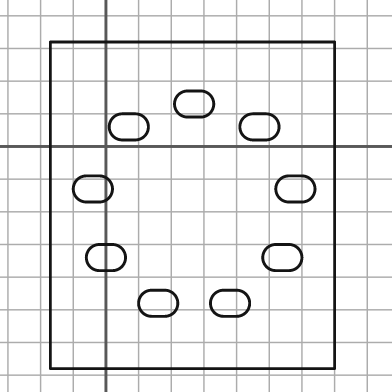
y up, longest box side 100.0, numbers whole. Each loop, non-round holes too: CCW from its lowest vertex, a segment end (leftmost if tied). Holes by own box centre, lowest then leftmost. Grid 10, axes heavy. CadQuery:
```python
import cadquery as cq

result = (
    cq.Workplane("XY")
    .moveTo(-17.0, -68.0)
    .lineTo(70.0, -68.0)
    .lineTo(70.0, 32.0)
    .lineTo(-17.0, 32.0)
    .close()
    .moveTo(14.0, -52.0)
    .lineTo(18.0, -52.0)
    .threePointArc((22.0, -48.0), (18.0, -44.0))
    .lineTo(14.0, -44.0)
    .threePointArc((10.0, -48.0), (14.0, -52.0))
    .close()
    .moveTo(36.0, -52.0)
    .lineTo(40.0, -52.0)
    .threePointArc((44.0, -48.0), (40.0, -44.0))
    .lineTo(36.0, -44.0)
    .threePointArc((32.0, -48.0), (36.0, -52.0))
    .close()
    .moveTo(-2.0, -38.0)
    .lineTo(2.0, -38.0)
    .threePointArc((6.0, -34.0), (2.0, -30.0))
    .lineTo(-2.0, -30.0)
    .threePointArc((-6.0, -34.0), (-2.0, -38.0))
    .close()
    .moveTo(52.0, -38.0)
    .lineTo(56.0, -38.0)
    .threePointArc((60.0, -34.0), (56.0, -30.0))
    .lineTo(52.0, -30.0)
    .threePointArc((48.0, -34.0), (52.0, -38.0))
    .close()
    .moveTo(-6.0, -17.0)
    .lineTo(-2.0, -17.0)
    .threePointArc((2.0, -13.0), (-2.0, -9.0))
    .lineTo(-6.0, -9.0)
    .threePointArc((-10.0, -13.0), (-6.0, -17.0))
    .close()
    .moveTo(56.0, -17.0)
    .lineTo(60.0, -17.0)
    .threePointArc((64.0, -13.0), (60.0, -9.0))
    .lineTo(56.0, -9.0)
    .threePointArc((52.0, -13.0), (56.0, -17.0))
    .close()
    .moveTo(5.0, 2.0)
    .lineTo(9.0, 2.0)
    .threePointArc((13.0, 6.0), (9.0, 10.0))
    .lineTo(5.0, 10.0)
    .threePointArc((1.0, 6.0), (5.0, 2.0))
    .close()
    .moveTo(45.0, 2.0)
    .lineTo(49.0, 2.0)
    .threePointArc((53.0, 6.0), (49.0, 10.0))
    .lineTo(45.0, 10.0)
    .threePointArc((41.0, 6.0), (45.0, 2.0))
    .close()
    .moveTo(25.0, 9.0)
    .lineTo(29.0, 9.0)
    .threePointArc((33.0, 13.0), (29.0, 17.0))
    .lineTo(25.0, 17.0)
    .threePointArc((21.0, 13.0), (25.0, 9.0))
    .close()
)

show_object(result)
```